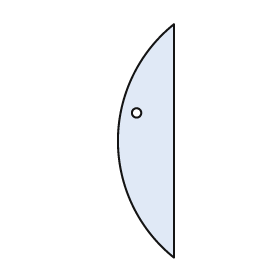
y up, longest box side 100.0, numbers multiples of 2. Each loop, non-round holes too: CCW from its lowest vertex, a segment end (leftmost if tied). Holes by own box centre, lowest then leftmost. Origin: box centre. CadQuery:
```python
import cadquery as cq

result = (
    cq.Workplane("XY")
    .moveTo(12.0, -50.0)
    .lineTo(12.0, 50.0)
    .threePointArc((-12.0, 0.0), (12.0, -50.0))
    .close()
    .moveTo(-4.0, 12.0)
    .circle(2.0)
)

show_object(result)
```